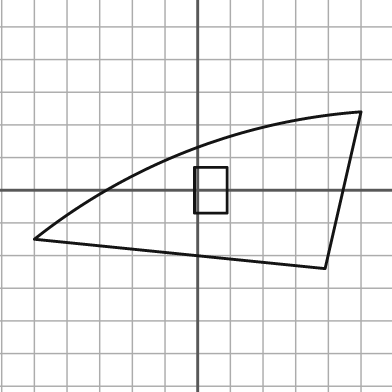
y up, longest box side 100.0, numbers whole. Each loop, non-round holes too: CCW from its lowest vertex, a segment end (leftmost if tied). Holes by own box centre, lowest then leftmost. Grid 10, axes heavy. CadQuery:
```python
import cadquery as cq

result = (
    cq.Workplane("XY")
    .moveTo(39.0, -24.0)
    .lineTo(50.0, 24.0)
    .threePointArc((-3.0, 12.0), (-50.0, -15.0))
    .close()
    .moveTo(-1.0, -7.0)
    .lineTo(9.0, -7.0)
    .lineTo(9.0, 7.0)
    .lineTo(-1.0, 7.0)
    .close()
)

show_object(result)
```